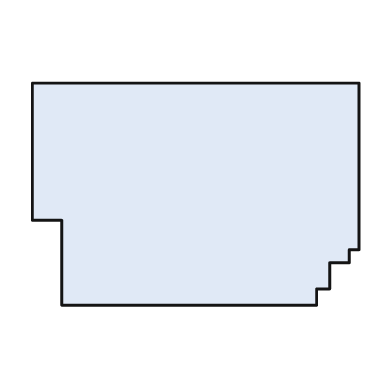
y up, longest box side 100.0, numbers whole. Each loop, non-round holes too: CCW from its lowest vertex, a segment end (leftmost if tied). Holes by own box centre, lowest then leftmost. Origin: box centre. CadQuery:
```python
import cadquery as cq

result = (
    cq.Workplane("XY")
    .moveTo(-41.0, -34.0)
    .lineTo(37.0, -34.0)
    .lineTo(37.0, -29.0)
    .lineTo(41.0, -29.0)
    .lineTo(41.0, -21.0)
    .lineTo(47.0, -21.0)
    .lineTo(47.0, -17.0)
    .lineTo(50.0, -17.0)
    .lineTo(50.0, 34.0)
    .lineTo(-50.0, 34.0)
    .lineTo(-50.0, -8.0)
    .lineTo(-41.0, -8.0)
    .close()
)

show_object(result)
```